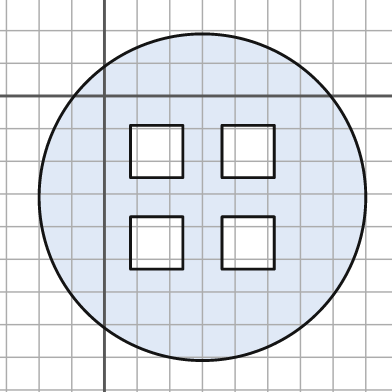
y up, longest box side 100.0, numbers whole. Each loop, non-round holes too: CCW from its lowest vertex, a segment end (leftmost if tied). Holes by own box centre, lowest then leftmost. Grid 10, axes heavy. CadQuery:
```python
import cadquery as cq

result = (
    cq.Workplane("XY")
    .moveTo(30.0, -31.0)
    .circle(50.0)
    .moveTo(8.0, -53.0)
    .lineTo(24.0, -53.0)
    .lineTo(24.0, -37.0)
    .lineTo(8.0, -37.0)
    .close()
    .moveTo(36.0, -53.0)
    .lineTo(52.0, -53.0)
    .lineTo(52.0, -37.0)
    .lineTo(36.0, -37.0)
    .close()
    .moveTo(8.0, -25.0)
    .lineTo(24.0, -25.0)
    .lineTo(24.0, -9.0)
    .lineTo(8.0, -9.0)
    .close()
    .moveTo(36.0, -25.0)
    .lineTo(52.0, -25.0)
    .lineTo(52.0, -9.0)
    .lineTo(36.0, -9.0)
    .close()
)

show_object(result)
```